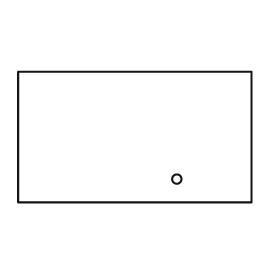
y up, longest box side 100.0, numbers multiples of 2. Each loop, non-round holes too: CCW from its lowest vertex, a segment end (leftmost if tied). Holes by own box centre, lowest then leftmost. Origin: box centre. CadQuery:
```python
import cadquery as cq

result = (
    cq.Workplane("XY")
    .moveTo(-50.0, -28.0)
    .lineTo(50.0, -28.0)
    .lineTo(50.0, 28.0)
    .lineTo(-50.0, 28.0)
    .close()
    .moveTo(18.0, -18.0)
    .circle(2.0)
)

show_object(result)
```